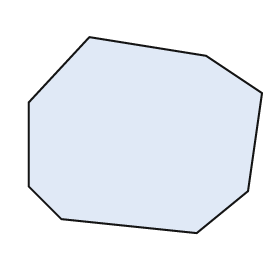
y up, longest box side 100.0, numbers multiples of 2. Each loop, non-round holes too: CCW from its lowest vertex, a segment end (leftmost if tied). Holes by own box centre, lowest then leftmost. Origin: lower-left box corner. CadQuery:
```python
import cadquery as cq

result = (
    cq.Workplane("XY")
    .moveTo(72.0, 0.0)
    .lineTo(94.0, 18.0)
    .lineTo(100.0, 60.0)
    .lineTo(76.0, 76.0)
    .lineTo(26.0, 84.0)
    .lineTo(0.0, 56.0)
    .lineTo(0.0, 20.0)
    .lineTo(14.0, 6.0)
    .close()
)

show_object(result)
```